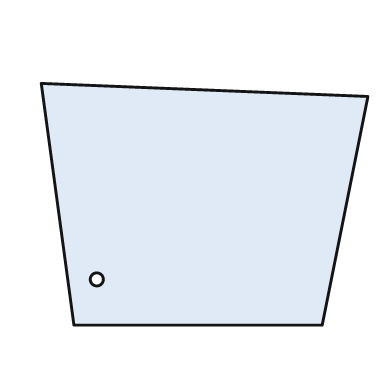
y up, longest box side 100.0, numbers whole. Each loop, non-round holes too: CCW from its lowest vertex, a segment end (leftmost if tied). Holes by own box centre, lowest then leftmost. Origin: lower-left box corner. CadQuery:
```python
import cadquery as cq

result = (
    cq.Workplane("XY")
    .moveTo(10.0, 0.0)
    .lineTo(86.0, 0.0)
    .lineTo(100.0, 70.0)
    .lineTo(0.0, 74.0)
    .close()
    .moveTo(17.0, 14.0)
    .circle(2.0)
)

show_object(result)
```